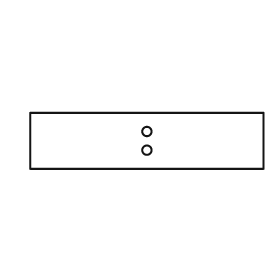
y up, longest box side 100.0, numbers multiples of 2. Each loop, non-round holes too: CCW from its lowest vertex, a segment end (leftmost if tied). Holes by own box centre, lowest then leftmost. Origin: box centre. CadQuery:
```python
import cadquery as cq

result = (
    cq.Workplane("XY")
    .moveTo(-50.0, -12.0)
    .lineTo(50.0, -12.0)
    .lineTo(50.0, 12.0)
    .lineTo(-50.0, 12.0)
    .close()
    .moveTo(0.0, -4.0)
    .circle(2.0)
    .moveTo(0.0, 4.0)
    .circle(2.0)
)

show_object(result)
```